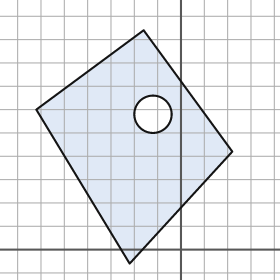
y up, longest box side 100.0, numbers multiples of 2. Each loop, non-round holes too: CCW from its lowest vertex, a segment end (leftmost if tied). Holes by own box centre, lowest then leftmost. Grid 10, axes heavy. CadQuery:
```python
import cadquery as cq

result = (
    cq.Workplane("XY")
    .moveTo(-22.0, -6.0)
    .lineTo(22.0, 42.0)
    .lineTo(-16.0, 94.0)
    .lineTo(-62.0, 60.0)
    .close()
    .moveTo(-12.0, 58.0)
    .circle(8.0)
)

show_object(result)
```